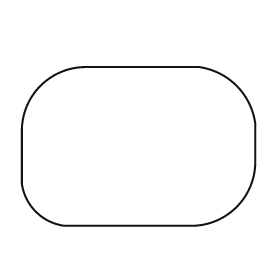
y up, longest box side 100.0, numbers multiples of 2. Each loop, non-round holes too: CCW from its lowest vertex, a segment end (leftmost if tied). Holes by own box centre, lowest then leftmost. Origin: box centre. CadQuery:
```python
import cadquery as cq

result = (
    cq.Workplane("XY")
    .moveTo(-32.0, -34.0)
    .lineTo(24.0, -34.0)
    .threePointArc((42.0, -26.0), (50.0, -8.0))
    .lineTo(50.0, 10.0)
    .threePointArc((42.0, 26.0), (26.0, 34.0))
    .lineTo(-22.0, 34.0)
    .threePointArc((-42.0, 26.0), (-50.0, 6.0))
    .lineTo(-50.0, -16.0)
    .threePointArc((-44.0, -28.0), (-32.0, -34.0))
    .close()
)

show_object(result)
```